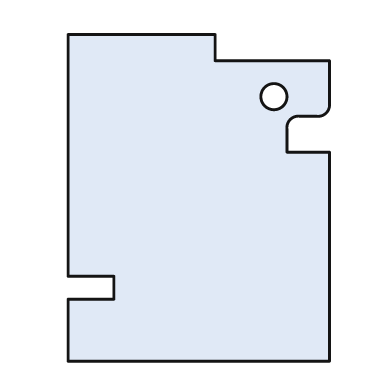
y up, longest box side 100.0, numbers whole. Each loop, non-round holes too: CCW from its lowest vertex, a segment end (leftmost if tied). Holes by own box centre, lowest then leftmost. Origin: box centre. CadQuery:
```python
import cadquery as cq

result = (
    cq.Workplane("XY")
    .moveTo(-40.0, -50.0)
    .lineTo(40.0, -50.0)
    .lineTo(40.0, 14.0)
    .lineTo(27.0, 14.0)
    .lineTo(27.0, 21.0)
    .threePointArc((28.0, 24.0), (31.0, 25.0))
    .lineTo(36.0, 25.0)
    .threePointArc((39.0, 26.0), (40.0, 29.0))
    .lineTo(40.0, 42.0)
    .lineTo(5.0, 42.0)
    .lineTo(5.0, 50.0)
    .lineTo(-40.0, 50.0)
    .lineTo(-40.0, -24.0)
    .lineTo(-26.0, -24.0)
    .lineTo(-26.0, -31.0)
    .lineTo(-40.0, -31.0)
    .close()
    .moveTo(23.0, 31.0)
    .circle(4.0)
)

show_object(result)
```